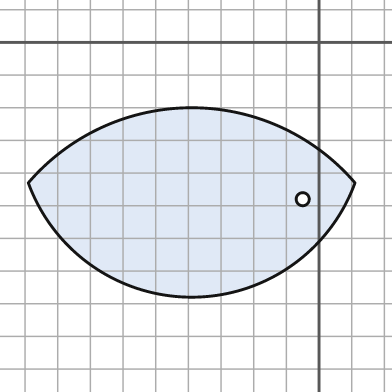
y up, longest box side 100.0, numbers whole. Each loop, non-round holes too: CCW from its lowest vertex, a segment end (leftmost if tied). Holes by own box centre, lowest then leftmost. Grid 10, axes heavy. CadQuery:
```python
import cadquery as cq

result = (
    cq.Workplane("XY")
    .moveTo(-89.0, -43.0)
    .threePointArc((-39.0, -78.0), (11.0, -43.0))
    .threePointArc((-39.0, -20.0), (-89.0, -43.0))
    .close()
    .moveTo(-5.0, -48.0)
    .circle(2.0)
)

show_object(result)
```